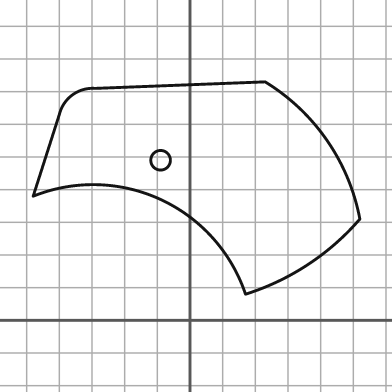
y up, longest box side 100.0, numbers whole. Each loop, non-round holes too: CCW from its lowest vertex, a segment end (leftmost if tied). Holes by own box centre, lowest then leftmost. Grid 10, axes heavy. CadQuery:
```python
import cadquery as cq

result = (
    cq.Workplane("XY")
    .moveTo(17.0, 8.0)
    .threePointArc((36.0, 17.0), (52.0, 31.0))
    .threePointArc((42.0, 55.0), (23.0, 73.0))
    .lineTo(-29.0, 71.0)
    .threePointArc((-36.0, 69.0), (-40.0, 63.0))
    .lineTo(-48.0, 38.0)
    .threePointArc((-9.0, 37.0), (17.0, 8.0))
    .close()
    .moveTo(-9.0, 49.0)
    .circle(3.0)
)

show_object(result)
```